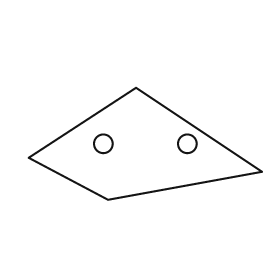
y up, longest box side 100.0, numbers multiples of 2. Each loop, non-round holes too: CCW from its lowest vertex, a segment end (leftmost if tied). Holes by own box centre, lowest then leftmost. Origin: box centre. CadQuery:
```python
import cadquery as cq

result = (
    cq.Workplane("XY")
    .moveTo(-16.0, -24.0)
    .lineTo(50.0, -12.0)
    .lineTo(-4.0, 24.0)
    .lineTo(-50.0, -6.0)
    .close()
    .moveTo(-18.0, 0.0)
    .circle(4.0)
    .moveTo(18.0, 0.0)
    .circle(4.0)
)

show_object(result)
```